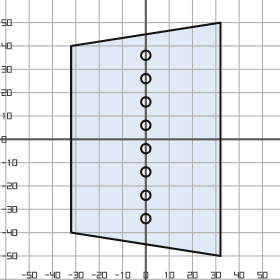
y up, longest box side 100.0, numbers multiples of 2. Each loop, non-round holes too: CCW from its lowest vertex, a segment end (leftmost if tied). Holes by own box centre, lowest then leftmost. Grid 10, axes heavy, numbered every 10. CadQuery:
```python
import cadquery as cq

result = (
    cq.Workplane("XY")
    .moveTo(32.0, -50.0)
    .lineTo(32.0, 50.0)
    .lineTo(-32.0, 40.0)
    .lineTo(-32.0, -40.0)
    .close()
    .moveTo(0.0, -34.0)
    .circle(2.0)
    .moveTo(0.0, -24.0)
    .circle(2.0)
    .moveTo(0.0, -14.0)
    .circle(2.0)
    .moveTo(0.0, -4.0)
    .circle(2.0)
    .moveTo(0.0, 6.0)
    .circle(2.0)
    .moveTo(0.0, 16.0)
    .circle(2.0)
    .moveTo(0.0, 26.0)
    .circle(2.0)
    .moveTo(0.0, 36.0)
    .circle(2.0)
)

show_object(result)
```